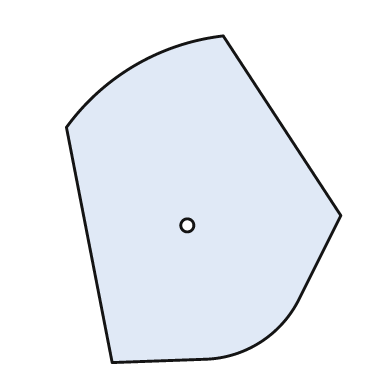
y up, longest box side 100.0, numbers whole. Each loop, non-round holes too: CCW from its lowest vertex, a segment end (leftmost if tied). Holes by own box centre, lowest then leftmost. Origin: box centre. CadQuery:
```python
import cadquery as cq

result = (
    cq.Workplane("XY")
    .moveTo(-28.0, -50.0)
    .lineTo(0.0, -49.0)
    .threePointArc((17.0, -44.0), (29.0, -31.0))
    .lineTo(42.0, -5.0)
    .lineTo(6.0, 50.0)
    .threePointArc((-21.0, 41.0), (-42.0, 22.0))
    .close()
    .moveTo(-5.0, -8.0)
    .circle(2.0)
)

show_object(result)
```